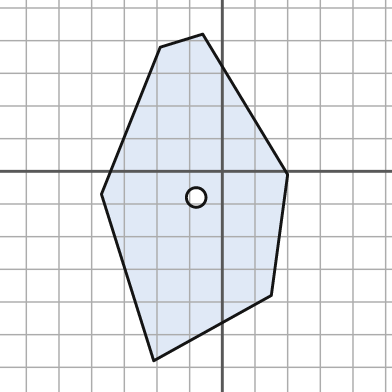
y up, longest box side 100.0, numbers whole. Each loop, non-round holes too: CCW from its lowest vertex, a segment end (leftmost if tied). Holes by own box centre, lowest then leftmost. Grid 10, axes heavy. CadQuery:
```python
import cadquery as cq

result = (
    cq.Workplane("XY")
    .moveTo(-21.0, -58.0)
    .lineTo(15.0, -38.0)
    .lineTo(20.0, -1.0)
    .lineTo(-6.0, 42.0)
    .lineTo(-19.0, 38.0)
    .lineTo(-37.0, -7.0)
    .close()
    .moveTo(-8.0, -8.0)
    .circle(3.0)
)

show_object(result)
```